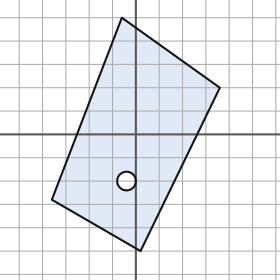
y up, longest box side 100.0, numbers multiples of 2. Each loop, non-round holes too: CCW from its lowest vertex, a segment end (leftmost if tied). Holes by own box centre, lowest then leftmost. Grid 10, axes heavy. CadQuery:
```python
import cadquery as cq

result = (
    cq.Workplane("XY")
    .moveTo(2.0, -50.0)
    .lineTo(36.0, 20.0)
    .lineTo(-6.0, 50.0)
    .lineTo(-36.0, -28.0)
    .close()
    .moveTo(-4.0, -20.0)
    .circle(4.0)
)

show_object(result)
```